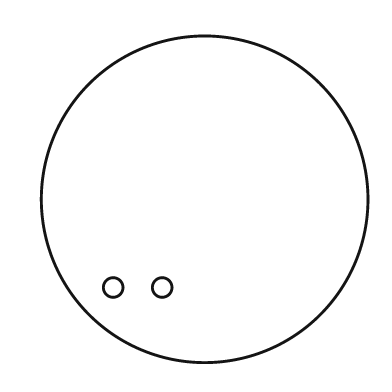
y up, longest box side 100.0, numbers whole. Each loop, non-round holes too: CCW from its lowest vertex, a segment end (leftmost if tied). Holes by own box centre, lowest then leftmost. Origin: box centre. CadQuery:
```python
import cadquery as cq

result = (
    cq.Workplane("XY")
    .moveTo(0.0, 0.0)
    .circle(50.0)
    .moveTo(-28.0, -27.0)
    .circle(3.0)
    .moveTo(-13.0, -27.0)
    .circle(3.0)
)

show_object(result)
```